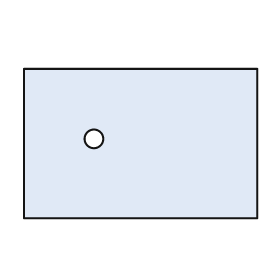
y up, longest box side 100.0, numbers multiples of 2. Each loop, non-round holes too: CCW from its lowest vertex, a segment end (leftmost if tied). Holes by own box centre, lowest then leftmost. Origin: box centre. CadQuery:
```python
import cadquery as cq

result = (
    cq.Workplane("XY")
    .moveTo(-50.0, -32.0)
    .lineTo(50.0, -32.0)
    .lineTo(50.0, 32.0)
    .lineTo(-50.0, 32.0)
    .close()
    .moveTo(-20.0, 2.0)
    .circle(4.0)
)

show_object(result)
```